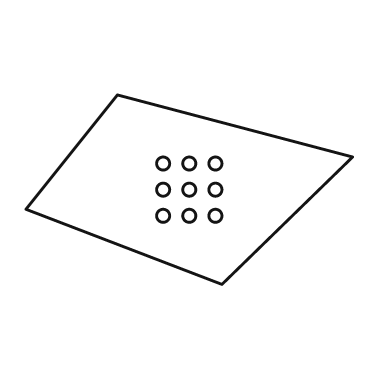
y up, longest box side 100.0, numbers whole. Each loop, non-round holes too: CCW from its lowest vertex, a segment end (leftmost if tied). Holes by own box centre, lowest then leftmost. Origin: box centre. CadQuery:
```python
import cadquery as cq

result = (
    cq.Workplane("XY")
    .moveTo(10.0, -29.0)
    .lineTo(50.0, 10.0)
    .lineTo(-22.0, 29.0)
    .lineTo(-50.0, -6.0)
    .close()
    .moveTo(-8.0, -8.0)
    .circle(2.0)
    .moveTo(0.0, -8.0)
    .circle(2.0)
    .moveTo(8.0, -8.0)
    .circle(2.0)
    .moveTo(-8.0, 0.0)
    .circle(2.0)
    .moveTo(0.0, 0.0)
    .circle(2.0)
    .moveTo(8.0, 0.0)
    .circle(2.0)
    .moveTo(-8.0, 8.0)
    .circle(2.0)
    .moveTo(0.0, 8.0)
    .circle(2.0)
    .moveTo(8.0, 8.0)
    .circle(2.0)
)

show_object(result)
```